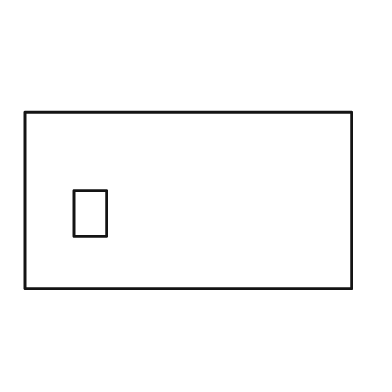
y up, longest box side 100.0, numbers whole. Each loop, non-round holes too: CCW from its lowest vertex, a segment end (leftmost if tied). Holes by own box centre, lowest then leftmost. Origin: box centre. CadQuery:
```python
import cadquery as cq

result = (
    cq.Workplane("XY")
    .moveTo(-50.0, -27.0)
    .lineTo(50.0, -27.0)
    .lineTo(50.0, 27.0)
    .lineTo(-50.0, 27.0)
    .close()
    .moveTo(-35.0, -11.0)
    .lineTo(-25.0, -11.0)
    .lineTo(-25.0, 3.0)
    .lineTo(-35.0, 3.0)
    .close()
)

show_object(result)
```